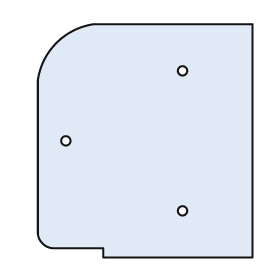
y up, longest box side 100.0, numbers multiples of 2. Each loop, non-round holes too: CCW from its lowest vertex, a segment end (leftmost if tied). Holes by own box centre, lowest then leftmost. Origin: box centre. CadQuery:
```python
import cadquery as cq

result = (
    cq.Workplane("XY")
    .moveTo(-18.0, -50.0)
    .lineTo(46.0, -50.0)
    .lineTo(46.0, 50.0)
    .lineTo(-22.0, 50.0)
    .threePointArc((-38.0, 42.0), (-46.0, 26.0))
    .lineTo(-46.0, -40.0)
    .threePointArc((-44.0, -44.0), (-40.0, -46.0))
    .lineTo(-18.0, -46.0)
    .close()
    .moveTo(16.0, -30.0)
    .circle(2.0)
    .moveTo(-34.0, 0.0)
    .circle(2.0)
    .moveTo(16.0, 30.0)
    .circle(2.0)
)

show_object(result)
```